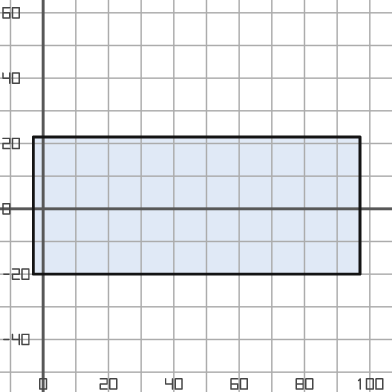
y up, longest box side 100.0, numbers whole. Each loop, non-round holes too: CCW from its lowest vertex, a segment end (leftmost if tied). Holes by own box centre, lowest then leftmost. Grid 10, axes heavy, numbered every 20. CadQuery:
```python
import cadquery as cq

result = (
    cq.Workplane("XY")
    .moveTo(-3.0, -20.0)
    .lineTo(97.0, -20.0)
    .lineTo(97.0, 22.0)
    .lineTo(-3.0, 22.0)
    .close()
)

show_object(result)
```